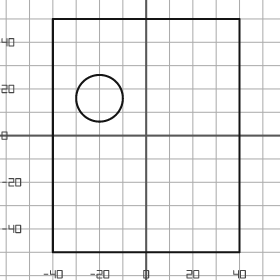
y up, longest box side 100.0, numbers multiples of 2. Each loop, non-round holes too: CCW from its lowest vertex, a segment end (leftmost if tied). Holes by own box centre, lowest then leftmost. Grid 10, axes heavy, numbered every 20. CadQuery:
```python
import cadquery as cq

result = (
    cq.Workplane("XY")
    .moveTo(-40.0, -50.0)
    .lineTo(40.0, -50.0)
    .lineTo(40.0, 50.0)
    .lineTo(-40.0, 50.0)
    .close()
    .moveTo(-20.0, 16.0)
    .circle(10.0)
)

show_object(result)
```